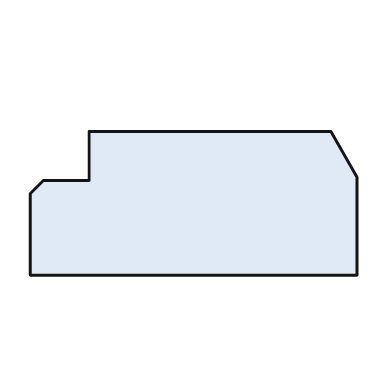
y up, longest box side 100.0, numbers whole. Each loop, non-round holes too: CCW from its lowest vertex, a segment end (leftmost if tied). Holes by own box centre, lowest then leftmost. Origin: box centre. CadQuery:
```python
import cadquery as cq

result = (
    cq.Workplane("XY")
    .moveTo(-50.0, -22.0)
    .lineTo(50.0, -22.0)
    .lineTo(50.0, 8.0)
    .lineTo(42.0, 22.0)
    .lineTo(-32.0, 22.0)
    .lineTo(-32.0, 7.0)
    .lineTo(-46.0, 7.0)
    .lineTo(-50.0, 3.0)
    .close()
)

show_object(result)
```